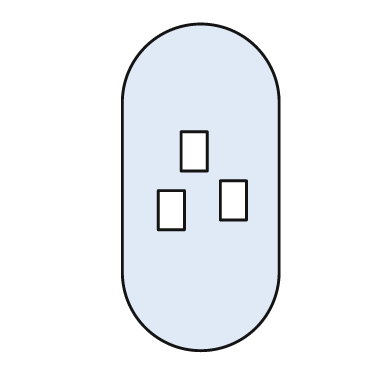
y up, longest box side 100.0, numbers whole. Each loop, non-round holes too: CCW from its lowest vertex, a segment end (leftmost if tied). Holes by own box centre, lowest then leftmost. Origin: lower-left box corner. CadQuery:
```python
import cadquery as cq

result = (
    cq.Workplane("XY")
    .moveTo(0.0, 24.0)
    .threePointArc((24.0, 0.0), (48.0, 24.0))
    .lineTo(48.0, 76.0)
    .threePointArc((24.0, 100.0), (0.0, 76.0))
    .close()
    .moveTo(11.0, 37.0)
    .lineTo(19.0, 37.0)
    .lineTo(19.0, 49.0)
    .lineTo(11.0, 49.0)
    .close()
    .moveTo(30.0, 40.0)
    .lineTo(38.0, 40.0)
    .lineTo(38.0, 52.0)
    .lineTo(30.0, 52.0)
    .close()
    .moveTo(18.0, 55.0)
    .lineTo(26.0, 55.0)
    .lineTo(26.0, 67.0)
    .lineTo(18.0, 67.0)
    .close()
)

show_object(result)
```